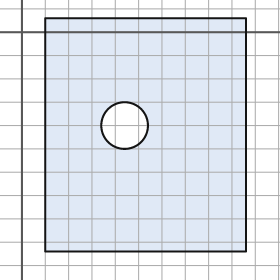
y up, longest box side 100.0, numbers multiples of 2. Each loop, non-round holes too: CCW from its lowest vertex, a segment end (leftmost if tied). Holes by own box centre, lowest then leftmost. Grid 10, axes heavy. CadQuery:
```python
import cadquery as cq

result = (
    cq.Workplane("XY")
    .moveTo(10.0, -94.0)
    .lineTo(96.0, -94.0)
    .lineTo(96.0, 6.0)
    .lineTo(10.0, 6.0)
    .close()
    .moveTo(44.0, -40.0)
    .circle(10.0)
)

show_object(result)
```